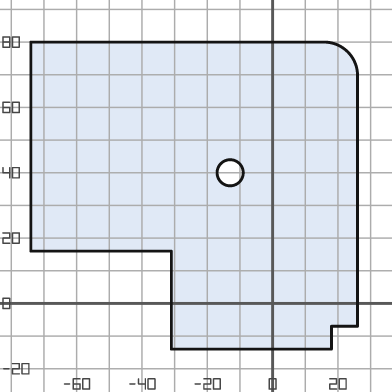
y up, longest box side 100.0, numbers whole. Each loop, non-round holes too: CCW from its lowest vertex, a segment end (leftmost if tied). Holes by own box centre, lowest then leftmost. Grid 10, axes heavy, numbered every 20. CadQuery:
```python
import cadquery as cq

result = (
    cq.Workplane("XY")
    .moveTo(-31.0, -14.0)
    .lineTo(18.0, -14.0)
    .lineTo(18.0, -7.0)
    .lineTo(26.0, -7.0)
    .lineTo(26.0, 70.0)
    .threePointArc((23.0, 77.0), (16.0, 80.0))
    .lineTo(-74.0, 80.0)
    .lineTo(-74.0, 16.0)
    .lineTo(-31.0, 16.0)
    .close()
    .moveTo(-13.0, 40.0)
    .circle(4.0)
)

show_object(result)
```